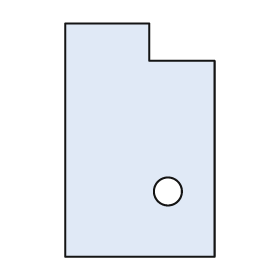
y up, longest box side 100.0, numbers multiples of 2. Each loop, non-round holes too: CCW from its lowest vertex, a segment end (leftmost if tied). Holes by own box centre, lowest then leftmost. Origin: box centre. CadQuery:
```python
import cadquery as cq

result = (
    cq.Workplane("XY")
    .moveTo(-32.0, -50.0)
    .lineTo(32.0, -50.0)
    .lineTo(32.0, 34.0)
    .lineTo(4.0, 34.0)
    .lineTo(4.0, 50.0)
    .lineTo(-32.0, 50.0)
    .close()
    .moveTo(12.0, -22.0)
    .circle(6.0)
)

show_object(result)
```